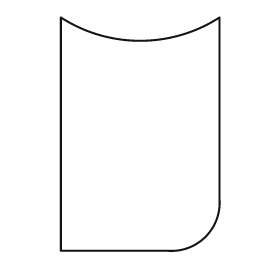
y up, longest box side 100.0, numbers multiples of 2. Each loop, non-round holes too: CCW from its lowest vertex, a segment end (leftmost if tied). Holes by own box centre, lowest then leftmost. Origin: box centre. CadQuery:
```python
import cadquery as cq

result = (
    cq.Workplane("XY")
    .moveTo(-34.0, -50.0)
    .lineTo(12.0, -50.0)
    .threePointArc((28.0, -44.0), (34.0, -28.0))
    .lineTo(34.0, 50.0)
    .threePointArc((0.0, 40.0), (-34.0, 50.0))
    .close()
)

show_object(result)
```